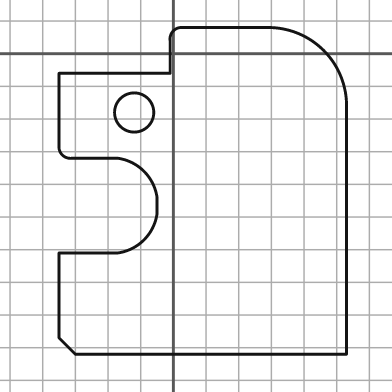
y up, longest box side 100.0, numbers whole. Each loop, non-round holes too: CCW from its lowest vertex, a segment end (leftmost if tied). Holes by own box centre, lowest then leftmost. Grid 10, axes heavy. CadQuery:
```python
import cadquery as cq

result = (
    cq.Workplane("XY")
    .moveTo(-30.0, -92.0)
    .lineTo(53.0, -92.0)
    .lineTo(53.0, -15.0)
    .threePointArc((46.0, 1.0), (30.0, 8.0))
    .lineTo(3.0, 8.0)
    .threePointArc((0.0, 7.0), (-1.0, 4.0))
    .lineTo(-1.0, -6.0)
    .lineTo(-35.0, -6.0)
    .lineTo(-35.0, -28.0)
    .threePointArc((-34.0, -31.0), (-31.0, -32.0))
    .lineTo(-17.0, -32.0)
    .threePointArc((-9.0, -36.0), (-5.0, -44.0))
    .lineTo(-5.0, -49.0)
    .threePointArc((-9.0, -57.0), (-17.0, -61.0))
    .lineTo(-35.0, -61.0)
    .lineTo(-35.0, -87.0)
    .close()
    .moveTo(-12.0, -18.0)
    .circle(6.0)
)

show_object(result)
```